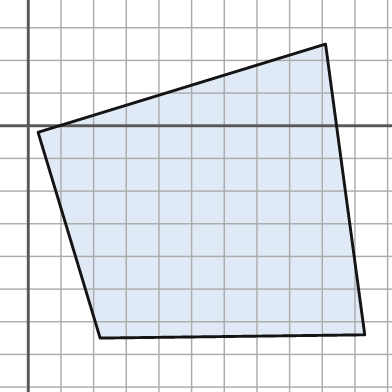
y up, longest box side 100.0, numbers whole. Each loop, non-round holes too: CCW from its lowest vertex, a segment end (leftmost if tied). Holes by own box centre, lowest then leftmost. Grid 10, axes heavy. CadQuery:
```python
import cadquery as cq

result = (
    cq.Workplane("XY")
    .moveTo(22.0, -65.0)
    .lineTo(103.0, -64.0)
    .lineTo(91.0, 25.0)
    .lineTo(3.0, -2.0)
    .close()
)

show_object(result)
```